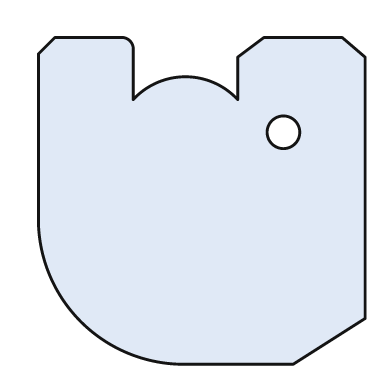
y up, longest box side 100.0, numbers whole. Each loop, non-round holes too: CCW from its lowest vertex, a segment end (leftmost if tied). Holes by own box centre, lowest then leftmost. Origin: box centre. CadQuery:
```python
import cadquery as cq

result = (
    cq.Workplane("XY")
    .moveTo(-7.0, -50.0)
    .lineTo(28.0, -50.0)
    .lineTo(50.0, -36.0)
    .lineTo(50.0, 44.0)
    .lineTo(43.0, 50.0)
    .lineTo(19.0, 50.0)
    .lineTo(11.0, 44.0)
    .lineTo(11.0, 31.0)
    .threePointArc((-5.0, 38.0), (-21.0, 31.0))
    .lineTo(-21.0, 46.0)
    .threePointArc((-22.0, 49.0), (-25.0, 50.0))
    .lineTo(-45.0, 50.0)
    .lineTo(-50.0, 45.0)
    .lineTo(-50.0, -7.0)
    .threePointArc((-37.0, -37.0), (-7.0, -50.0))
    .close()
    .moveTo(25.0, 21.0)
    .circle(5.0)
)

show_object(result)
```